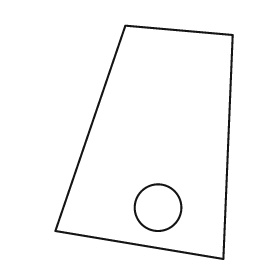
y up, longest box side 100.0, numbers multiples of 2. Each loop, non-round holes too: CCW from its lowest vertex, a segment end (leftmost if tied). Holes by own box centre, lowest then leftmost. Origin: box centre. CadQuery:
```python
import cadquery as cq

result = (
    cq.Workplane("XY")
    .moveTo(34.0, -50.0)
    .lineTo(38.0, 46.0)
    .lineTo(-8.0, 50.0)
    .lineTo(-38.0, -38.0)
    .close()
    .moveTo(6.0, -28.0)
    .circle(10.0)
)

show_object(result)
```